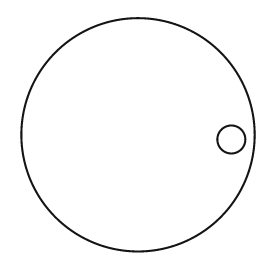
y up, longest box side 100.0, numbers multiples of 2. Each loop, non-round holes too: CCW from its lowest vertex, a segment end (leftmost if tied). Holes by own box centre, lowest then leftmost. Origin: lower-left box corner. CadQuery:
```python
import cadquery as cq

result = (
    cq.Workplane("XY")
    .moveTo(50.0, 50.0)
    .circle(50.0)
    .moveTo(90.0, 48.0)
    .circle(6.0)
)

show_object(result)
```